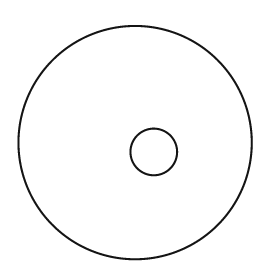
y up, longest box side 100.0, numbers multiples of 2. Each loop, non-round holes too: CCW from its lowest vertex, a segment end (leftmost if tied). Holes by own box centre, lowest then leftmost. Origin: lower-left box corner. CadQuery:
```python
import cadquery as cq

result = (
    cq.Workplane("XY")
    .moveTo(50.0, 50.0)
    .circle(50.0)
    .moveTo(58.0, 46.0)
    .circle(10.0)
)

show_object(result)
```